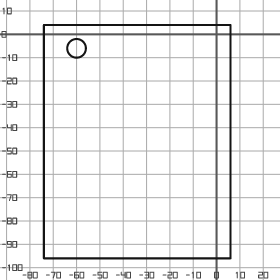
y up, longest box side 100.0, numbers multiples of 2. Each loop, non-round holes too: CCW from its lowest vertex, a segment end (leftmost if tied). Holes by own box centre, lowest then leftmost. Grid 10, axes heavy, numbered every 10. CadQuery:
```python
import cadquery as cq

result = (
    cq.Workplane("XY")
    .moveTo(-74.0, -96.0)
    .lineTo(6.0, -96.0)
    .lineTo(6.0, 4.0)
    .lineTo(-74.0, 4.0)
    .close()
    .moveTo(-60.0, -6.0)
    .circle(4.0)
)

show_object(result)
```